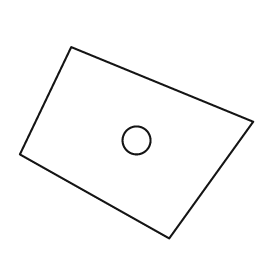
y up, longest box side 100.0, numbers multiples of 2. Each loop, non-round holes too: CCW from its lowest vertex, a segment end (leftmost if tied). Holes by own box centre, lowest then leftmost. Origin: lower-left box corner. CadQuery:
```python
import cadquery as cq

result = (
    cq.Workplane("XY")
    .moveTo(64.0, 0.0)
    .lineTo(100.0, 50.0)
    .lineTo(22.0, 82.0)
    .lineTo(0.0, 36.0)
    .close()
    .moveTo(50.0, 42.0)
    .circle(6.0)
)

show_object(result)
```